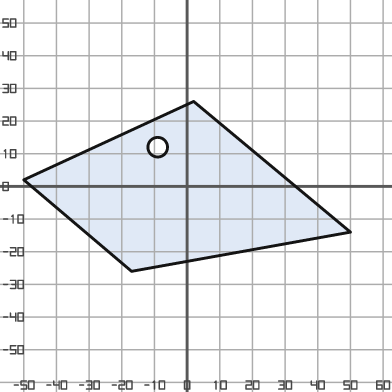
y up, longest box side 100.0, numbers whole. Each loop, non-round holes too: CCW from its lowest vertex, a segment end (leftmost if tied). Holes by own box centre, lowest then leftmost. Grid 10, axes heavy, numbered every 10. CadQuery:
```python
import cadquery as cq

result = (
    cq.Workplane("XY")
    .moveTo(-17.0, -26.0)
    .lineTo(50.0, -14.0)
    .lineTo(2.0, 26.0)
    .lineTo(-50.0, 2.0)
    .close()
    .moveTo(-9.0, 12.0)
    .circle(3.0)
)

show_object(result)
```